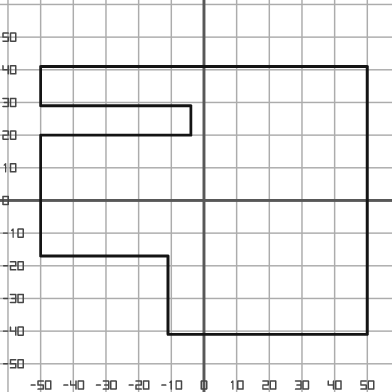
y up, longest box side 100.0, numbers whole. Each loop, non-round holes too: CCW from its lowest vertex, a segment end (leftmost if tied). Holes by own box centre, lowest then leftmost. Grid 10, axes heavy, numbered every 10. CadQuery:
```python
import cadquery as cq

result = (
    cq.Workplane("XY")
    .moveTo(-11.0, -41.0)
    .lineTo(50.0, -41.0)
    .lineTo(50.0, 41.0)
    .lineTo(-50.0, 41.0)
    .lineTo(-50.0, 29.0)
    .lineTo(-4.0, 29.0)
    .lineTo(-4.0, 20.0)
    .lineTo(-50.0, 20.0)
    .lineTo(-50.0, -17.0)
    .lineTo(-11.0, -17.0)
    .close()
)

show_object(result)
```